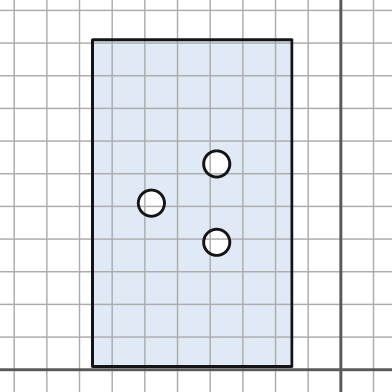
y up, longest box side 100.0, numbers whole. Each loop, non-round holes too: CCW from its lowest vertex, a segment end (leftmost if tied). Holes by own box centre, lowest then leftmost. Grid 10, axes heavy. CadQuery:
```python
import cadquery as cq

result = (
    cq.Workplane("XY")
    .moveTo(-76.0, 1.0)
    .lineTo(-15.0, 1.0)
    .lineTo(-15.0, 101.0)
    .lineTo(-76.0, 101.0)
    .close()
    .moveTo(-38.0, 39.0)
    .circle(4.0)
    .moveTo(-58.0, 51.0)
    .circle(4.0)
    .moveTo(-38.0, 63.0)
    .circle(4.0)
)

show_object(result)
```